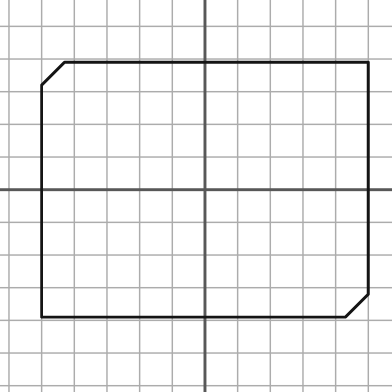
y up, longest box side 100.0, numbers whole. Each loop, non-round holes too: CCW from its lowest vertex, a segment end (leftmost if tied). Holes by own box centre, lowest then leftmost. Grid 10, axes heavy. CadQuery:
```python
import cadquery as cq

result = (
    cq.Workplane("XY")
    .moveTo(-50.0, -39.0)
    .lineTo(43.0, -39.0)
    .lineTo(50.0, -32.0)
    .lineTo(50.0, 39.0)
    .lineTo(-43.0, 39.0)
    .lineTo(-50.0, 32.0)
    .close()
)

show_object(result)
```